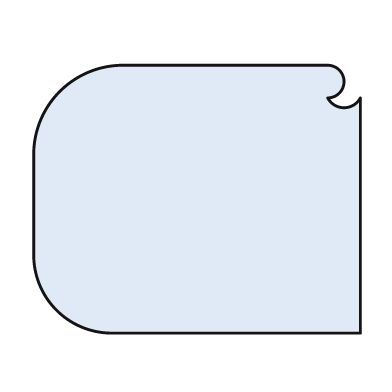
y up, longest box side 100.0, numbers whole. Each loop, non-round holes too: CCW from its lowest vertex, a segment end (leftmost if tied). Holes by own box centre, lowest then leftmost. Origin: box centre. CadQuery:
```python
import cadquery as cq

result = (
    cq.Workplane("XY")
    .moveTo(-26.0, -41.0)
    .lineTo(50.0, -41.0)
    .lineTo(50.0, 31.0)
    .threePointArc((45.0, 28.0), (40.0, 31.0))
    .threePointArc((45.0, 36.0), (40.0, 41.0))
    .lineTo(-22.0, 41.0)
    .threePointArc((-42.0, 33.0), (-50.0, 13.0))
    .lineTo(-50.0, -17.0)
    .threePointArc((-43.0, -34.0), (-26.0, -41.0))
    .close()
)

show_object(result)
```